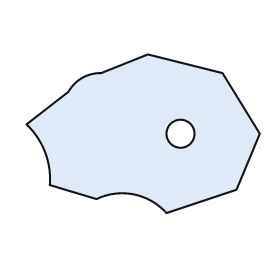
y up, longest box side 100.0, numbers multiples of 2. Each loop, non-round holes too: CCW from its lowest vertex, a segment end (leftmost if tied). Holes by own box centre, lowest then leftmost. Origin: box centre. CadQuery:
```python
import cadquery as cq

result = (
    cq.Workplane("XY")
    .moveTo(10.0, -34.0)
    .lineTo(40.0, -24.0)
    .lineTo(50.0, 0.0)
    .lineTo(34.0, 26.0)
    .lineTo(2.0, 34.0)
    .lineTo(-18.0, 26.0)
    .threePointArc((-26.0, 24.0), (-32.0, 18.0))
    .lineTo(-50.0, 4.0)
    .threePointArc((-42.0, -8.0), (-40.0, -22.0))
    .lineTo(-20.0, -28.0)
    .threePointArc((-4.0, -26.0), (10.0, -34.0))
    .close()
    .moveTo(16.0, 0.0)
    .circle(6.0)
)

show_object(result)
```